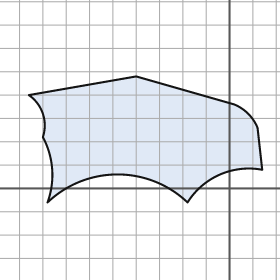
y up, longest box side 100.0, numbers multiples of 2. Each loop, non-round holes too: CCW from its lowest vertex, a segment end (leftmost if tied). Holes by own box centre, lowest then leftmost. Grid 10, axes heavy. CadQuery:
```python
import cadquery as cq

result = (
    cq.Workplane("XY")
    .moveTo(-78.0, -6.0)
    .threePointArc((-48.0, 6.0), (-18.0, -6.0))
    .threePointArc((-4.0, 6.0), (14.0, 8.0))
    .lineTo(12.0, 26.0)
    .threePointArc((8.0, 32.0), (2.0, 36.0))
    .lineTo(-40.0, 48.0)
    .lineTo(-86.0, 40.0)
    .threePointArc((-80.0, 32.0), (-80.0, 22.0))
    .threePointArc((-76.0, 8.0), (-78.0, -6.0))
    .close()
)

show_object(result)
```